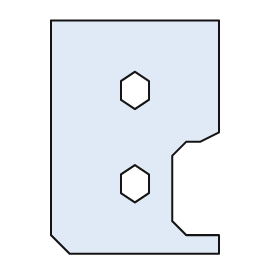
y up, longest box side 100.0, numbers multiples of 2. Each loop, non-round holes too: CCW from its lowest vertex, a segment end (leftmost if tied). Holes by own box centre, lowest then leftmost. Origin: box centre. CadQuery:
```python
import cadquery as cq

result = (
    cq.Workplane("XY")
    .moveTo(-28.0, -50.0)
    .lineTo(36.0, -50.0)
    .lineTo(36.0, -42.0)
    .lineTo(22.0, -42.0)
    .lineTo(16.0, -36.0)
    .lineTo(16.0, -8.0)
    .lineTo(22.0, -2.0)
    .lineTo(28.0, -2.0)
    .lineTo(36.0, 2.0)
    .lineTo(36.0, 50.0)
    .lineTo(-36.0, 50.0)
    .lineTo(-36.0, -42.0)
    .close()
    .moveTo(0.0, -28.0)
    .lineTo(6.0, -24.0)
    .lineTo(6.0, -16.0)
    .lineTo(0.0, -12.0)
    .lineTo(-6.0, -16.0)
    .lineTo(-6.0, -24.0)
    .close()
    .moveTo(0.0, 12.0)
    .lineTo(6.0, 16.0)
    .lineTo(6.0, 24.0)
    .lineTo(0.0, 28.0)
    .lineTo(-6.0, 24.0)
    .lineTo(-6.0, 16.0)
    .close()
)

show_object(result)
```